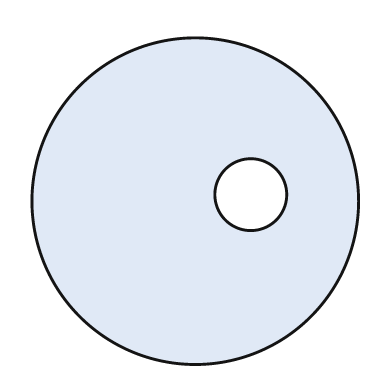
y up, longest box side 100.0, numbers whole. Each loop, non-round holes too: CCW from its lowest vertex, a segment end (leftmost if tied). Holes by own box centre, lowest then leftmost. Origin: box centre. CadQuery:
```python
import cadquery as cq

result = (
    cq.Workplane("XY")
    .moveTo(0.0, 0.0)
    .circle(50.0)
    .moveTo(17.0, 2.0)
    .circle(11.0)
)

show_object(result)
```